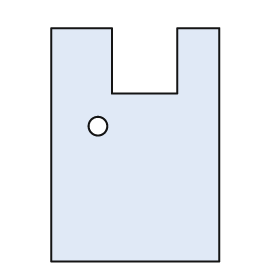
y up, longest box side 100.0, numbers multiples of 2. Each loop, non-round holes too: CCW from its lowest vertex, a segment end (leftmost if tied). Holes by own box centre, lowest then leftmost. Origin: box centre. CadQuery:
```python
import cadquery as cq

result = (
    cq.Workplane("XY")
    .moveTo(-36.0, -50.0)
    .lineTo(36.0, -50.0)
    .lineTo(36.0, 50.0)
    .lineTo(18.0, 50.0)
    .lineTo(18.0, 22.0)
    .lineTo(-10.0, 22.0)
    .lineTo(-10.0, 50.0)
    .lineTo(-36.0, 50.0)
    .close()
    .moveTo(-16.0, 8.0)
    .circle(4.0)
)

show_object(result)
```